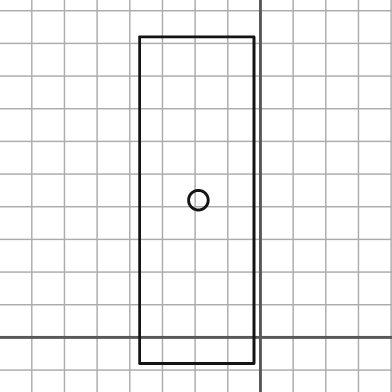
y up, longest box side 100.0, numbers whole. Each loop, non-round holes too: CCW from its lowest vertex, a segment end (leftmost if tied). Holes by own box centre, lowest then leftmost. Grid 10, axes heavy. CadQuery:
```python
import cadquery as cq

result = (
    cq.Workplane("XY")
    .moveTo(-37.0, -8.0)
    .lineTo(-2.0, -8.0)
    .lineTo(-2.0, 92.0)
    .lineTo(-37.0, 92.0)
    .close()
    .moveTo(-19.0, 42.0)
    .circle(3.0)
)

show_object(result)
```